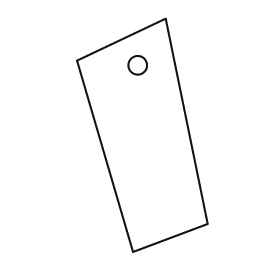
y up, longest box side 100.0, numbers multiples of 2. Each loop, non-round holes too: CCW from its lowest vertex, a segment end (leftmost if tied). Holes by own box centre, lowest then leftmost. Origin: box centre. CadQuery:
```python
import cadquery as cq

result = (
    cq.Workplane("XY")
    .moveTo(-4.0, -50.0)
    .lineTo(28.0, -38.0)
    .lineTo(10.0, 50.0)
    .lineTo(-28.0, 32.0)
    .close()
    .moveTo(-2.0, 30.0)
    .circle(4.0)
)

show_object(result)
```